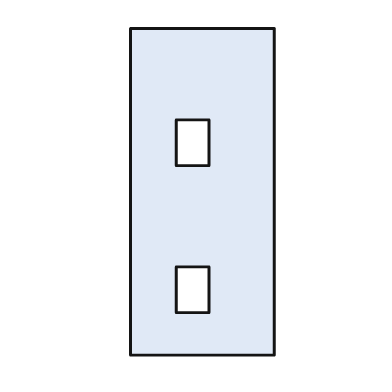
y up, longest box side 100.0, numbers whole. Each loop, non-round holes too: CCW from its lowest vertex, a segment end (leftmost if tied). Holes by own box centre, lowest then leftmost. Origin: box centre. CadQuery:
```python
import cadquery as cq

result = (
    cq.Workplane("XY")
    .moveTo(-22.0, -50.0)
    .lineTo(22.0, -50.0)
    .lineTo(22.0, 50.0)
    .lineTo(-22.0, 50.0)
    .close()
    .moveTo(-8.0, -37.0)
    .lineTo(2.0, -37.0)
    .lineTo(2.0, -23.0)
    .lineTo(-8.0, -23.0)
    .close()
    .moveTo(-8.0, 8.0)
    .lineTo(2.0, 8.0)
    .lineTo(2.0, 22.0)
    .lineTo(-8.0, 22.0)
    .close()
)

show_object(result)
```